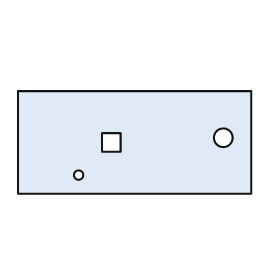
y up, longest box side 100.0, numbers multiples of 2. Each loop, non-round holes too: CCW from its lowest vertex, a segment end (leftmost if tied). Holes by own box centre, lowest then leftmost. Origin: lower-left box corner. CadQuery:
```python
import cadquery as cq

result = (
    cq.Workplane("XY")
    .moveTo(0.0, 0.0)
    .lineTo(100.0, 0.0)
    .lineTo(100.0, 44.0)
    .lineTo(0.0, 44.0)
    .close()
    .moveTo(26.0, 8.0)
    .circle(2.0)
    .moveTo(36.0, 18.0)
    .lineTo(44.0, 18.0)
    .lineTo(44.0, 26.0)
    .lineTo(36.0, 26.0)
    .close()
    .moveTo(88.0, 24.0)
    .circle(4.0)
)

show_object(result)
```